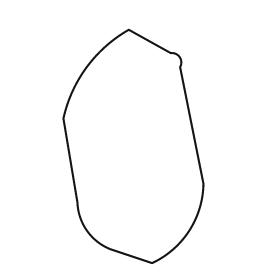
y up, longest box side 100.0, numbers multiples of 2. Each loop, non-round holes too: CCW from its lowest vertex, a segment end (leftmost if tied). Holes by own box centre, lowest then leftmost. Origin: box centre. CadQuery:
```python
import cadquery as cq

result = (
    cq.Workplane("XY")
    .moveTo(8.0, -50.0)
    .threePointArc((24.0, -36.0), (30.0, -16.0))
    .lineTo(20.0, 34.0)
    .threePointArc((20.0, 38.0), (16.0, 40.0))
    .lineTo(-2.0, 50.0)
    .threePointArc((-20.0, 34.0), (-30.0, 12.0))
    .lineTo(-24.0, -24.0)
    .threePointArc((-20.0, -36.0), (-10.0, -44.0))
    .close()
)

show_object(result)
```